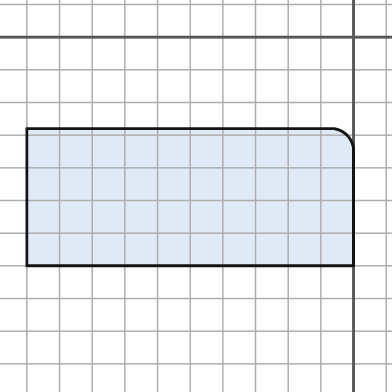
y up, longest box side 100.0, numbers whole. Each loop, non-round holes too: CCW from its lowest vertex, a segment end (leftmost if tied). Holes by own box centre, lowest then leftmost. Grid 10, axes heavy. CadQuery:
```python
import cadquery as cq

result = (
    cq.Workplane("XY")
    .moveTo(-100.0, -70.0)
    .lineTo(0.0, -70.0)
    .lineTo(0.0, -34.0)
    .threePointArc((-2.0, -30.0), (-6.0, -28.0))
    .lineTo(-100.0, -28.0)
    .close()
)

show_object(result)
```